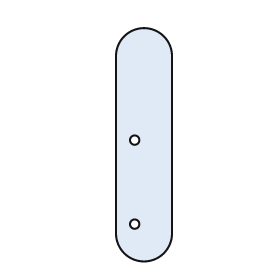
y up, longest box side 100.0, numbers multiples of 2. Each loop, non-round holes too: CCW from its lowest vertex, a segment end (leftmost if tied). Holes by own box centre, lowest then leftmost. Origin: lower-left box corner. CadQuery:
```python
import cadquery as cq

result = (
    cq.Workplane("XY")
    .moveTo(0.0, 12.0)
    .threePointArc((12.0, 0.0), (24.0, 12.0))
    .lineTo(24.0, 88.0)
    .threePointArc((12.0, 100.0), (0.0, 88.0))
    .close()
    .moveTo(8.0, 16.0)
    .circle(2.0)
    .moveTo(8.0, 52.0)
    .circle(2.0)
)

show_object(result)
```